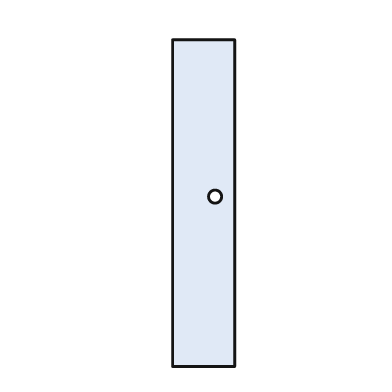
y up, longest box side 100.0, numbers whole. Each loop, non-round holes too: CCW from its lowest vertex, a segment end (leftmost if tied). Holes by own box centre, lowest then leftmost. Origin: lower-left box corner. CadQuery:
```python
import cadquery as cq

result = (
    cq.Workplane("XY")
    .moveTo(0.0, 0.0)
    .lineTo(19.0, 0.0)
    .lineTo(19.0, 100.0)
    .lineTo(0.0, 100.0)
    .close()
    .moveTo(13.0, 52.0)
    .circle(2.0)
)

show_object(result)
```